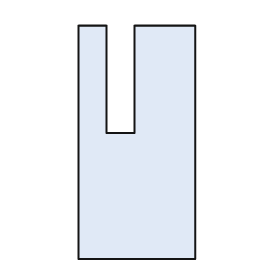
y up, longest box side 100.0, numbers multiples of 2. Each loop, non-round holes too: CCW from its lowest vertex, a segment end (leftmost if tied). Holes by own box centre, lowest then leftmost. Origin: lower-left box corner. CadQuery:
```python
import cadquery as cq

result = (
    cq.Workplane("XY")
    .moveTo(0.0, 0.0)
    .lineTo(50.0, 0.0)
    .lineTo(50.0, 100.0)
    .lineTo(24.0, 100.0)
    .lineTo(24.0, 54.0)
    .lineTo(12.0, 54.0)
    .lineTo(12.0, 100.0)
    .lineTo(0.0, 100.0)
    .close()
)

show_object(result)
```